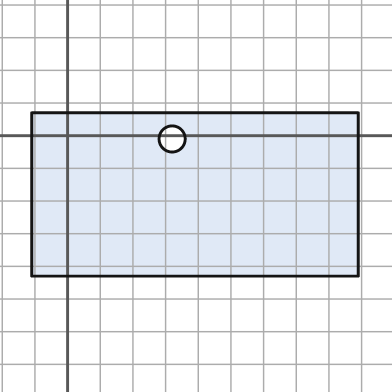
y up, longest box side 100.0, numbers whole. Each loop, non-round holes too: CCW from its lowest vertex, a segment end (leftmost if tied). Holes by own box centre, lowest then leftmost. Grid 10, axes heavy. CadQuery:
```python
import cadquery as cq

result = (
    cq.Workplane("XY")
    .moveTo(-11.0, -43.0)
    .lineTo(89.0, -43.0)
    .lineTo(89.0, 7.0)
    .lineTo(-11.0, 7.0)
    .close()
    .moveTo(32.0, -1.0)
    .circle(4.0)
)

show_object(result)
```